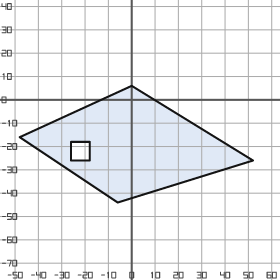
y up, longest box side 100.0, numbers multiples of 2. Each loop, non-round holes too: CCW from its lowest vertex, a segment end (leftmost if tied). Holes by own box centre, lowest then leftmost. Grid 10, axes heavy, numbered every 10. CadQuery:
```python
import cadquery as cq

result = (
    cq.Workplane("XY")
    .moveTo(-6.0, -44.0)
    .lineTo(52.0, -26.0)
    .lineTo(0.0, 6.0)
    .lineTo(-48.0, -16.0)
    .close()
    .moveTo(-26.0, -26.0)
    .lineTo(-18.0, -26.0)
    .lineTo(-18.0, -18.0)
    .lineTo(-26.0, -18.0)
    .close()
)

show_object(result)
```